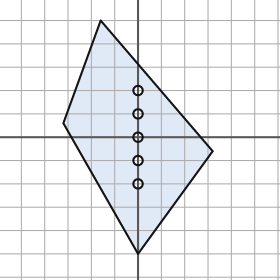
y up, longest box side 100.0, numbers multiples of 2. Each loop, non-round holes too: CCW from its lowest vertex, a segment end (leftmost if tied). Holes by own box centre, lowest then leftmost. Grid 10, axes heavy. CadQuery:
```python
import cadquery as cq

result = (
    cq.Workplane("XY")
    .moveTo(0.0, -50.0)
    .lineTo(32.0, -6.0)
    .lineTo(-16.0, 50.0)
    .lineTo(-32.0, 6.0)
    .close()
    .moveTo(0.0, -20.0)
    .circle(2.0)
    .moveTo(0.0, -10.0)
    .circle(2.0)
    .moveTo(0.0, 0.0)
    .circle(2.0)
    .moveTo(0.0, 10.0)
    .circle(2.0)
    .moveTo(0.0, 20.0)
    .circle(2.0)
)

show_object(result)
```